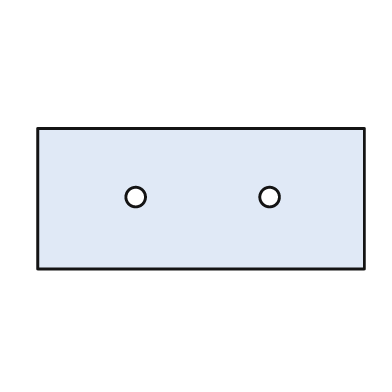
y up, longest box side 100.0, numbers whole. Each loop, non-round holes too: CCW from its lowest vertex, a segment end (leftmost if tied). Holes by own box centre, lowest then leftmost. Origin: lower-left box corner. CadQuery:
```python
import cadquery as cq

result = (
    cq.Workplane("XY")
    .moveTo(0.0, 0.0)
    .lineTo(100.0, 0.0)
    .lineTo(100.0, 43.0)
    .lineTo(0.0, 43.0)
    .close()
    .moveTo(30.0, 22.0)
    .circle(3.0)
    .moveTo(71.0, 22.0)
    .circle(3.0)
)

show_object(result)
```